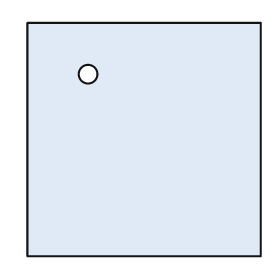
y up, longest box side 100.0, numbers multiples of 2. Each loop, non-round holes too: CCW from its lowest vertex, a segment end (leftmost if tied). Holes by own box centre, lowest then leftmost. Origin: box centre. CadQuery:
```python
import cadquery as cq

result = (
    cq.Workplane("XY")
    .moveTo(-50.0, -50.0)
    .lineTo(50.0, -50.0)
    .lineTo(50.0, 50.0)
    .lineTo(-50.0, 50.0)
    .close()
    .moveTo(-24.0, 28.0)
    .circle(4.0)
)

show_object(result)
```